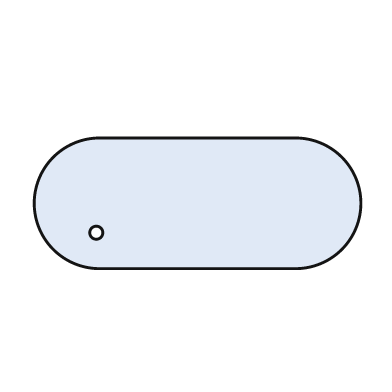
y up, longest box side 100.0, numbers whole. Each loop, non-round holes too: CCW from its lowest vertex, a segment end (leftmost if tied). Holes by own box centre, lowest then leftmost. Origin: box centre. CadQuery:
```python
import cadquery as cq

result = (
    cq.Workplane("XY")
    .moveTo(-30.0, -20.0)
    .lineTo(30.0, -20.0)
    .threePointArc((50.0, 0.0), (30.0, 20.0))
    .lineTo(-30.0, 20.0)
    .threePointArc((-50.0, 0.0), (-30.0, -20.0))
    .close()
    .moveTo(-31.0, -9.0)
    .circle(2.0)
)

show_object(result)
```